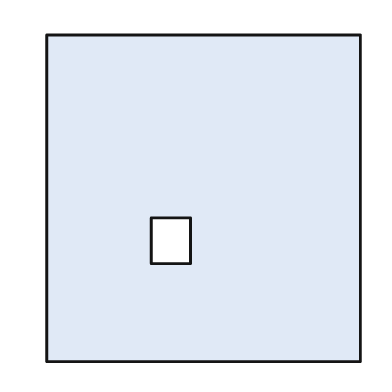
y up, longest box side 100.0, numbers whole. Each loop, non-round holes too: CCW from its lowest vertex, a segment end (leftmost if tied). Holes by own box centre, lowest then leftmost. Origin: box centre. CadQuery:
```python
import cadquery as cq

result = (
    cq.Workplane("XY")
    .moveTo(-48.0, -50.0)
    .lineTo(48.0, -50.0)
    .lineTo(48.0, 50.0)
    .lineTo(-48.0, 50.0)
    .close()
    .moveTo(-16.0, -20.0)
    .lineTo(-4.0, -20.0)
    .lineTo(-4.0, -6.0)
    .lineTo(-16.0, -6.0)
    .close()
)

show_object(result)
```